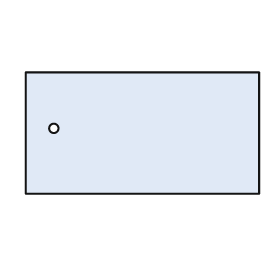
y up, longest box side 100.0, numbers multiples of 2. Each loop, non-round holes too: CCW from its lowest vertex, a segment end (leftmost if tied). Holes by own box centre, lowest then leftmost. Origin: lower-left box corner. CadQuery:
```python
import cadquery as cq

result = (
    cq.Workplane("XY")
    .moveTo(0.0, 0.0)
    .lineTo(100.0, 0.0)
    .lineTo(100.0, 52.0)
    .lineTo(0.0, 52.0)
    .close()
    .moveTo(12.0, 28.0)
    .circle(2.0)
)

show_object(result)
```